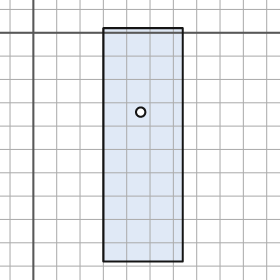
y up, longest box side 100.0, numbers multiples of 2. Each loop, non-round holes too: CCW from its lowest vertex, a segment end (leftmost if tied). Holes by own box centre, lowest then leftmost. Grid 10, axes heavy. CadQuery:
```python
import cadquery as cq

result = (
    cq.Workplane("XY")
    .moveTo(30.0, -98.0)
    .lineTo(64.0, -98.0)
    .lineTo(64.0, 2.0)
    .lineTo(30.0, 2.0)
    .close()
    .moveTo(46.0, -34.0)
    .circle(2.0)
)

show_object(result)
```